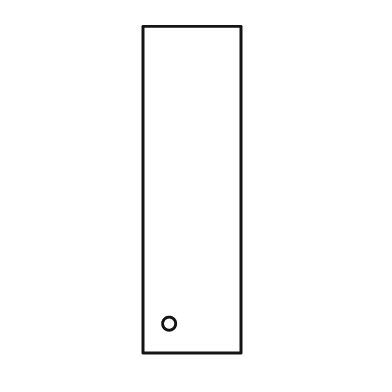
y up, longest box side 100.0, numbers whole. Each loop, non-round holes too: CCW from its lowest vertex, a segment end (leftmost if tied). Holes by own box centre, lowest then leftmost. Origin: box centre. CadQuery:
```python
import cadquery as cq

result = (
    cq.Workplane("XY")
    .moveTo(-15.0, -50.0)
    .lineTo(15.0, -50.0)
    .lineTo(15.0, 50.0)
    .lineTo(-15.0, 50.0)
    .close()
    .moveTo(-7.0, -41.0)
    .circle(2.0)
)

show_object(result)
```